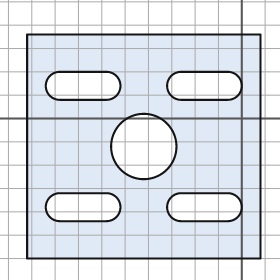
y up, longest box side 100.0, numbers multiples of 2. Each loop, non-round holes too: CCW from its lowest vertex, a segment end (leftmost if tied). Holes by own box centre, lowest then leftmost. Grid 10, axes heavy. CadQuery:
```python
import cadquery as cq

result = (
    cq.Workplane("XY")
    .moveTo(-92.0, -60.0)
    .lineTo(8.0, -60.0)
    .lineTo(8.0, 36.0)
    .lineTo(-92.0, 36.0)
    .close()
    .moveTo(-78.0, -44.0)
    .lineTo(-58.0, -44.0)
    .threePointArc((-52.0, -38.0), (-58.0, -32.0))
    .lineTo(-78.0, -32.0)
    .threePointArc((-84.0, -38.0), (-78.0, -44.0))
    .close()
    .moveTo(-26.0, -44.0)
    .lineTo(-6.0, -44.0)
    .threePointArc((0.0, -38.0), (-6.0, -32.0))
    .lineTo(-26.0, -32.0)
    .threePointArc((-32.0, -38.0), (-26.0, -44.0))
    .close()
    .moveTo(-42.0, -12.0)
    .circle(14.0)
    .moveTo(-78.0, 8.0)
    .lineTo(-58.0, 8.0)
    .threePointArc((-52.0, 14.0), (-58.0, 20.0))
    .lineTo(-78.0, 20.0)
    .threePointArc((-84.0, 14.0), (-78.0, 8.0))
    .close()
    .moveTo(-26.0, 8.0)
    .lineTo(-6.0, 8.0)
    .threePointArc((0.0, 14.0), (-6.0, 20.0))
    .lineTo(-26.0, 20.0)
    .threePointArc((-32.0, 14.0), (-26.0, 8.0))
    .close()
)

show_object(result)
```